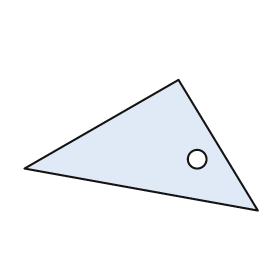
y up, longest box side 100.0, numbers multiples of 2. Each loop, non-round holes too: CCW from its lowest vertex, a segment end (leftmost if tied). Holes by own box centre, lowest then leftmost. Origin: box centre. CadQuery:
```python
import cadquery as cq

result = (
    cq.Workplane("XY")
    .moveTo(50.0, -28.0)
    .lineTo(16.0, 28.0)
    .lineTo(-50.0, -10.0)
    .close()
    .moveTo(24.0, -6.0)
    .circle(4.0)
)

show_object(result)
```